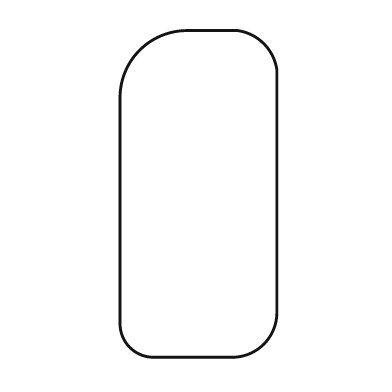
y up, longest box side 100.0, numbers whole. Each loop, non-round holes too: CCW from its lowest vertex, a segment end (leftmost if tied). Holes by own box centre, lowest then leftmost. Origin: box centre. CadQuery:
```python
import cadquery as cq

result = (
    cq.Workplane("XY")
    .moveTo(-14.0, -50.0)
    .lineTo(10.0, -50.0)
    .threePointArc((20.0, -46.0), (24.0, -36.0))
    .lineTo(24.0, 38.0)
    .threePointArc((20.0, 46.0), (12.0, 50.0))
    .lineTo(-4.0, 50.0)
    .threePointArc((-18.0, 44.0), (-24.0, 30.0))
    .lineTo(-24.0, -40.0)
    .threePointArc((-21.0, -47.0), (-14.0, -50.0))
    .close()
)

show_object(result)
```